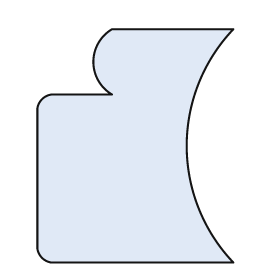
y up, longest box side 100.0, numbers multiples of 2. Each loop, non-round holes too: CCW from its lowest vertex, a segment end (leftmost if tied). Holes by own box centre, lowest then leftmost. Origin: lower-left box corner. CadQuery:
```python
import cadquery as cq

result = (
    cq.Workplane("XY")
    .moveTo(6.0, 0.0)
    .lineTo(84.0, 0.0)
    .threePointArc((64.0, 50.0), (84.0, 100.0))
    .lineTo(32.0, 100.0)
    .threePointArc((24.0, 86.0), (32.0, 72.0))
    .lineTo(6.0, 72.0)
    .threePointArc((2.0, 70.0), (0.0, 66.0))
    .lineTo(0.0, 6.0)
    .threePointArc((2.0, 2.0), (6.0, 0.0))
    .close()
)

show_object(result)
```